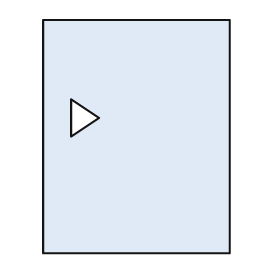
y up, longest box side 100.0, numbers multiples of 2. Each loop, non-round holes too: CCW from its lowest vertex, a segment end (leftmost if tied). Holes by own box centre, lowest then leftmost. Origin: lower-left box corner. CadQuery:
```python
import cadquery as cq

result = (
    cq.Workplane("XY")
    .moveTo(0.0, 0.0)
    .lineTo(80.0, 0.0)
    .lineTo(80.0, 100.0)
    .lineTo(0.0, 100.0)
    .close()
    .moveTo(12.0, 50.0)
    .lineTo(24.0, 58.0)
    .lineTo(12.0, 66.0)
    .close()
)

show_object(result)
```